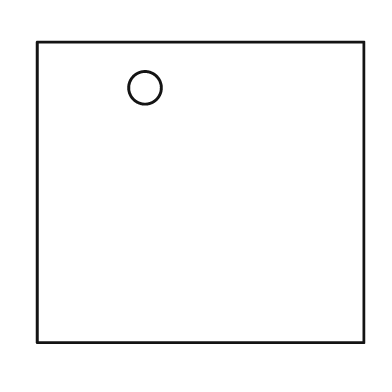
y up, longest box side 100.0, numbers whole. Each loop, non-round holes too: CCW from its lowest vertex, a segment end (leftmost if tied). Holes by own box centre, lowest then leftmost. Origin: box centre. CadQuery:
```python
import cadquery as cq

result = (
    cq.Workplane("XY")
    .moveTo(-50.0, -46.0)
    .lineTo(50.0, -46.0)
    .lineTo(50.0, 46.0)
    .lineTo(-50.0, 46.0)
    .close()
    .moveTo(-17.0, 32.0)
    .circle(5.0)
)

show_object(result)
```